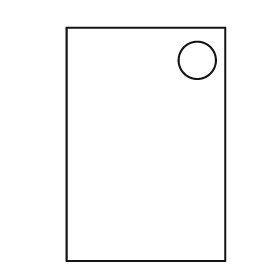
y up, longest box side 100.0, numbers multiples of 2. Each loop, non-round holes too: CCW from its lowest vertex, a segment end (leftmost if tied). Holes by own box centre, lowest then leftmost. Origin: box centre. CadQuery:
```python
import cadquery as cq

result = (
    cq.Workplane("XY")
    .moveTo(-34.0, -50.0)
    .lineTo(34.0, -50.0)
    .lineTo(34.0, 50.0)
    .lineTo(-34.0, 50.0)
    .close()
    .moveTo(22.0, 36.0)
    .circle(8.0)
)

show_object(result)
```